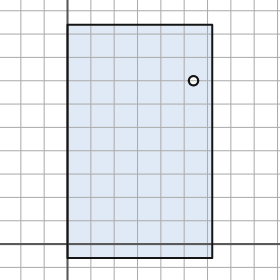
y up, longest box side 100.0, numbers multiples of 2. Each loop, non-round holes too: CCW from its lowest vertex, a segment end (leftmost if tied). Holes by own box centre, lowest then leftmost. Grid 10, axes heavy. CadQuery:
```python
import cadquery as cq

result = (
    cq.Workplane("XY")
    .moveTo(0.0, -6.0)
    .lineTo(62.0, -6.0)
    .lineTo(62.0, 94.0)
    .lineTo(0.0, 94.0)
    .close()
    .moveTo(54.0, 70.0)
    .circle(2.0)
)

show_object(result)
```